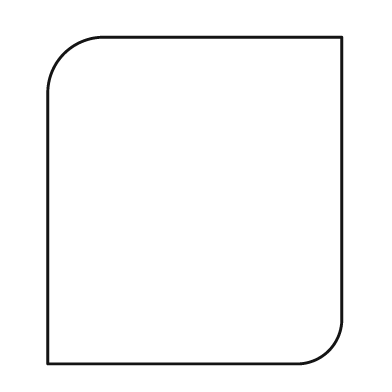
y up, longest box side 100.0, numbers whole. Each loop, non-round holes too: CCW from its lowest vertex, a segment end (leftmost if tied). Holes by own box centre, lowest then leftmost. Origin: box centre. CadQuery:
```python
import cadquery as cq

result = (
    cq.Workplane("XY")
    .moveTo(-45.0, -50.0)
    .lineTo(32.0, -50.0)
    .threePointArc((41.0, -46.0), (45.0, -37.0))
    .lineTo(45.0, 50.0)
    .lineTo(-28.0, 50.0)
    .threePointArc((-40.0, 45.0), (-45.0, 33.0))
    .close()
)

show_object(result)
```